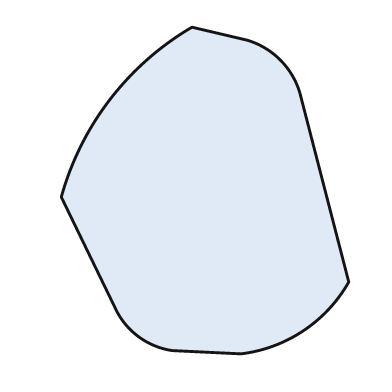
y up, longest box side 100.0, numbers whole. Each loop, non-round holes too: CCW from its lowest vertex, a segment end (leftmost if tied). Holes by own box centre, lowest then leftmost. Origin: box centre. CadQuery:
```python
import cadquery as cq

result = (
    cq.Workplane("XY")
    .moveTo(11.0, -50.0)
    .threePointArc((30.0, -43.0), (44.0, -28.0))
    .lineTo(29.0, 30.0)
    .threePointArc((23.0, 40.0), (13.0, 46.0))
    .lineTo(-4.0, 50.0)
    .threePointArc((-29.0, 28.0), (-44.0, -2.0))
    .lineTo(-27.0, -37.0)
    .threePointArc((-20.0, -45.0), (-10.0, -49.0))
    .close()
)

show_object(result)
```